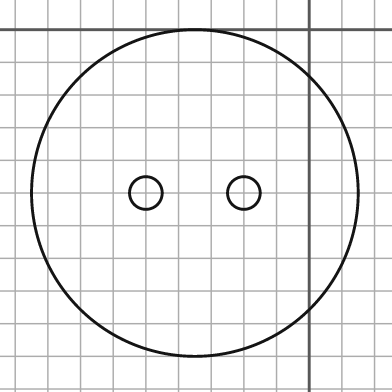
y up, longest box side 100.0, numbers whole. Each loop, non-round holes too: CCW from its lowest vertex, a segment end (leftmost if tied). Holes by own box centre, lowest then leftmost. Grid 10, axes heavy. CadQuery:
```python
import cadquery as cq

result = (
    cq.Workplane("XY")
    .moveTo(-35.0, -50.0)
    .circle(50.0)
    .moveTo(-50.0, -50.0)
    .circle(5.0)
    .moveTo(-20.0, -50.0)
    .circle(5.0)
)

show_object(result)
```